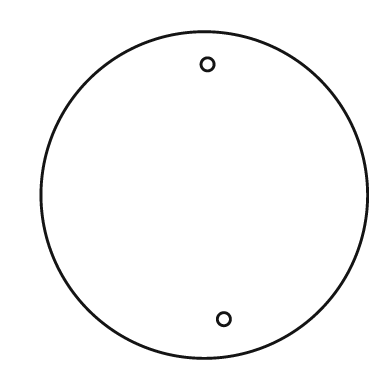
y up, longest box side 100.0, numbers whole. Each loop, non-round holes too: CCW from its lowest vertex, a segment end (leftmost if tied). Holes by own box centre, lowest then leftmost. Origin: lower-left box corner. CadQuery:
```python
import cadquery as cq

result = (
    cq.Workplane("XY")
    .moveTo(50.0, 50.0)
    .circle(50.0)
    .moveTo(56.0, 12.0)
    .circle(2.0)
    .moveTo(51.0, 90.0)
    .circle(2.0)
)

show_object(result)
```